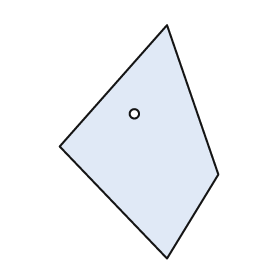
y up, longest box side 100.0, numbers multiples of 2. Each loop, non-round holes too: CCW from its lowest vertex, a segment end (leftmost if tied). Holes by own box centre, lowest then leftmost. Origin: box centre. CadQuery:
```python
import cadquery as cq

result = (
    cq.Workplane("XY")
    .moveTo(12.0, -50.0)
    .lineTo(34.0, -14.0)
    .lineTo(12.0, 50.0)
    .lineTo(-34.0, -2.0)
    .close()
    .moveTo(-2.0, 12.0)
    .circle(2.0)
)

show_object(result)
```